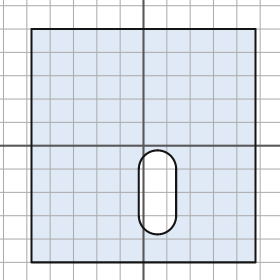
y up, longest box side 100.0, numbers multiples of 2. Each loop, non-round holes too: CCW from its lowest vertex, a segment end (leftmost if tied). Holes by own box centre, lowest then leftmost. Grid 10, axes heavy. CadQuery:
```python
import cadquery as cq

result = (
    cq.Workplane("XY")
    .moveTo(-48.0, -50.0)
    .lineTo(48.0, -50.0)
    .lineTo(48.0, 50.0)
    .lineTo(-48.0, 50.0)
    .close()
    .moveTo(-2.0, -30.0)
    .threePointArc((6.0, -38.0), (14.0, -30.0))
    .lineTo(14.0, -10.0)
    .threePointArc((6.0, -2.0), (-2.0, -10.0))
    .close()
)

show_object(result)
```